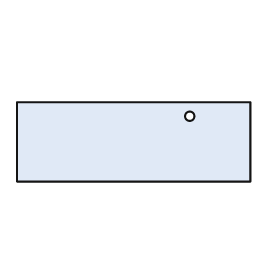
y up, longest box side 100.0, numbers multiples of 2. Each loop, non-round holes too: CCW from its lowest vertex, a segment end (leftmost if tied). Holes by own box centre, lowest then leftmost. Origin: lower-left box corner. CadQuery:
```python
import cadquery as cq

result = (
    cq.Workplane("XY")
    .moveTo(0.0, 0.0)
    .lineTo(100.0, 0.0)
    .lineTo(100.0, 34.0)
    .lineTo(0.0, 34.0)
    .close()
    .moveTo(74.0, 28.0)
    .circle(2.0)
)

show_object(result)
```